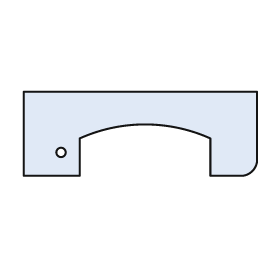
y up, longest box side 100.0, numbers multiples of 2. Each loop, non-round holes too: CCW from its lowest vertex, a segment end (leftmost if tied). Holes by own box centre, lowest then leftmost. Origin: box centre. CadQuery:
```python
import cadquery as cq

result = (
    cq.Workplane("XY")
    .moveTo(-50.0, -18.0)
    .lineTo(-26.0, -18.0)
    .lineTo(-26.0, -2.0)
    .threePointArc((2.0, 4.0), (30.0, -2.0))
    .lineTo(30.0, -18.0)
    .lineTo(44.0, -18.0)
    .threePointArc((48.0, -16.0), (50.0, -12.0))
    .lineTo(50.0, 18.0)
    .lineTo(-50.0, 18.0)
    .close()
    .moveTo(-34.0, -8.0)
    .circle(2.0)
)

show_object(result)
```